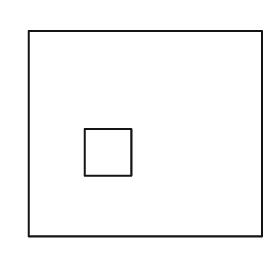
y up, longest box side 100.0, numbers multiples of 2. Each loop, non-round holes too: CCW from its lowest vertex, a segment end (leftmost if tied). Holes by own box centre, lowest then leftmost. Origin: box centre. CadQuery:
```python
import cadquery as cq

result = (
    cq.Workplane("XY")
    .moveTo(-50.0, -44.0)
    .lineTo(50.0, -44.0)
    .lineTo(50.0, 44.0)
    .lineTo(-50.0, 44.0)
    .close()
    .moveTo(-26.0, -18.0)
    .lineTo(-6.0, -18.0)
    .lineTo(-6.0, 2.0)
    .lineTo(-26.0, 2.0)
    .close()
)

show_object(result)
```